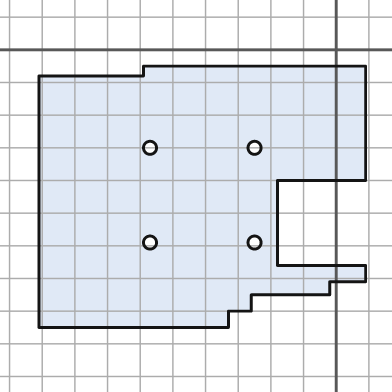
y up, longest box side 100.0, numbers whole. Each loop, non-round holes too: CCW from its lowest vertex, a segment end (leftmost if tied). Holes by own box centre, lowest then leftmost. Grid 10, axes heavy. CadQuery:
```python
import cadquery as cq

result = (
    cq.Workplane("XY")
    .moveTo(-91.0, -85.0)
    .lineTo(-33.0, -85.0)
    .lineTo(-33.0, -80.0)
    .lineTo(-26.0, -80.0)
    .lineTo(-26.0, -75.0)
    .lineTo(-2.0, -75.0)
    .lineTo(-2.0, -71.0)
    .lineTo(9.0, -71.0)
    .lineTo(9.0, -66.0)
    .lineTo(-18.0, -66.0)
    .lineTo(-18.0, -40.0)
    .lineTo(9.0, -40.0)
    .lineTo(9.0, -5.0)
    .lineTo(-59.0, -5.0)
    .lineTo(-59.0, -8.0)
    .lineTo(-91.0, -8.0)
    .close()
    .moveTo(-57.0, -59.0)
    .circle(2.0)
    .moveTo(-25.0, -59.0)
    .circle(2.0)
    .moveTo(-57.0, -30.0)
    .circle(2.0)
    .moveTo(-25.0, -30.0)
    .circle(2.0)
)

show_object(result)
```